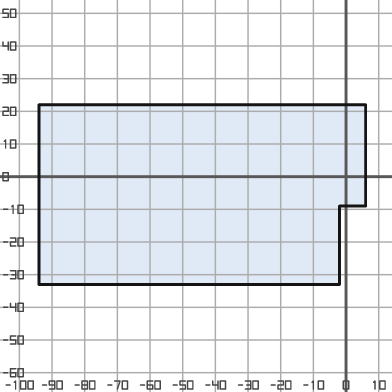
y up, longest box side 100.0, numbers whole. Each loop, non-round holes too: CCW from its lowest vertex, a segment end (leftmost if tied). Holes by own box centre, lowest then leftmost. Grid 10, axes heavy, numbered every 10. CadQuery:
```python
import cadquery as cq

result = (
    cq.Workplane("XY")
    .moveTo(-94.0, -33.0)
    .lineTo(-2.0, -33.0)
    .lineTo(-2.0, -9.0)
    .lineTo(6.0, -9.0)
    .lineTo(6.0, 22.0)
    .lineTo(-94.0, 22.0)
    .close()
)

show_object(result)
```